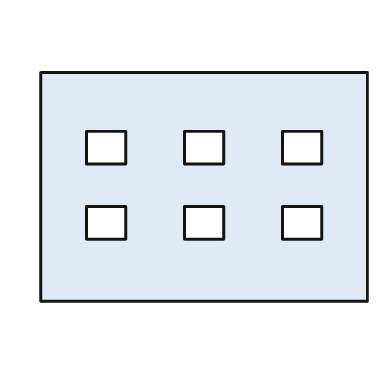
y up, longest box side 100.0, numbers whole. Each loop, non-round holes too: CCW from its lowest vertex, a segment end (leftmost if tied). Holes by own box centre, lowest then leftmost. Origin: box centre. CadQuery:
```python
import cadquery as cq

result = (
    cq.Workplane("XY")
    .moveTo(-50.0, -35.0)
    .lineTo(50.0, -35.0)
    .lineTo(50.0, 35.0)
    .lineTo(-50.0, 35.0)
    .close()
    .moveTo(-36.0, -16.0)
    .lineTo(-24.0, -16.0)
    .lineTo(-24.0, -6.0)
    .lineTo(-36.0, -6.0)
    .close()
    .moveTo(-6.0, -16.0)
    .lineTo(6.0, -16.0)
    .lineTo(6.0, -6.0)
    .lineTo(-6.0, -6.0)
    .close()
    .moveTo(24.0, -16.0)
    .lineTo(36.0, -16.0)
    .lineTo(36.0, -6.0)
    .lineTo(24.0, -6.0)
    .close()
    .moveTo(-36.0, 7.0)
    .lineTo(-24.0, 7.0)
    .lineTo(-24.0, 17.0)
    .lineTo(-36.0, 17.0)
    .close()
    .moveTo(-6.0, 7.0)
    .lineTo(6.0, 7.0)
    .lineTo(6.0, 17.0)
    .lineTo(-6.0, 17.0)
    .close()
    .moveTo(24.0, 7.0)
    .lineTo(36.0, 7.0)
    .lineTo(36.0, 17.0)
    .lineTo(24.0, 17.0)
    .close()
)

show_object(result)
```